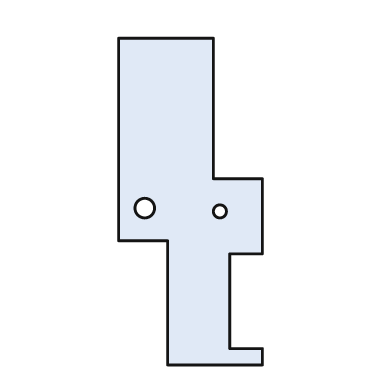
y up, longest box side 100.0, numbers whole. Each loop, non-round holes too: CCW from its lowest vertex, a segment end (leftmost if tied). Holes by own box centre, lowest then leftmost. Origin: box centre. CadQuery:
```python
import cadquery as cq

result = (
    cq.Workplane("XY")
    .moveTo(-7.0, -50.0)
    .lineTo(22.0, -50.0)
    .lineTo(22.0, -45.0)
    .lineTo(12.0, -45.0)
    .lineTo(12.0, -16.0)
    .lineTo(22.0, -16.0)
    .lineTo(22.0, 7.0)
    .lineTo(7.0, 7.0)
    .lineTo(7.0, 50.0)
    .lineTo(-22.0, 50.0)
    .lineTo(-22.0, -12.0)
    .lineTo(-7.0, -12.0)
    .close()
    .moveTo(9.0, -3.0)
    .circle(2.0)
    .moveTo(-14.0, -2.0)
    .circle(3.0)
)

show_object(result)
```